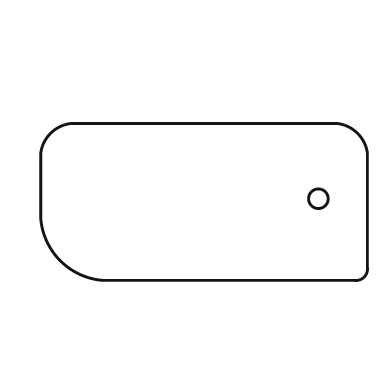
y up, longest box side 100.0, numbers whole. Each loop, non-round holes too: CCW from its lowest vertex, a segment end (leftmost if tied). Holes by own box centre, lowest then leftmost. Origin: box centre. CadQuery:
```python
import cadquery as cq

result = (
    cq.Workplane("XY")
    .moveTo(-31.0, -24.0)
    .lineTo(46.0, -24.0)
    .threePointArc((49.0, -23.0), (50.0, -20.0))
    .lineTo(50.0, 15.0)
    .threePointArc((47.0, 21.0), (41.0, 24.0))
    .lineTo(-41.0, 24.0)
    .threePointArc((-47.0, 21.0), (-50.0, 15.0))
    .lineTo(-50.0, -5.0)
    .threePointArc((-44.0, -18.0), (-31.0, -24.0))
    .close()
    .moveTo(35.0, 1.0)
    .circle(3.0)
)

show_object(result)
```